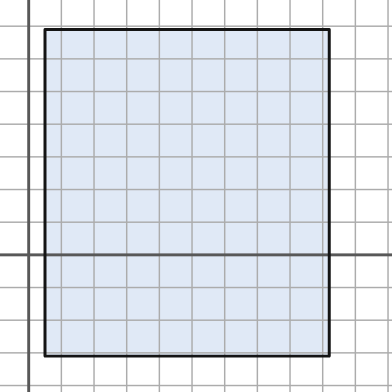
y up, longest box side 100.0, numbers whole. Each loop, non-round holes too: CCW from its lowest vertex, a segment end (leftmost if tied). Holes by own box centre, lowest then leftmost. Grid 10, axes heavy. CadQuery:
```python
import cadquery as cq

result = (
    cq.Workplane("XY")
    .moveTo(5.0, -31.0)
    .lineTo(92.0, -31.0)
    .lineTo(92.0, 69.0)
    .lineTo(5.0, 69.0)
    .close()
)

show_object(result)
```